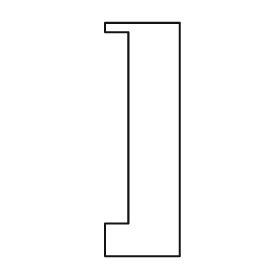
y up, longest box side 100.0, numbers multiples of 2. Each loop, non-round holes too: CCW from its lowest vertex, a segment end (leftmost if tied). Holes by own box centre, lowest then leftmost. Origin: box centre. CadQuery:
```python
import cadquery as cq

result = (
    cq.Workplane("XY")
    .moveTo(-16.0, -50.0)
    .lineTo(16.0, -50.0)
    .lineTo(16.0, 50.0)
    .lineTo(-16.0, 50.0)
    .lineTo(-16.0, 46.0)
    .lineTo(-6.0, 46.0)
    .lineTo(-6.0, -36.0)
    .lineTo(-16.0, -36.0)
    .close()
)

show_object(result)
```